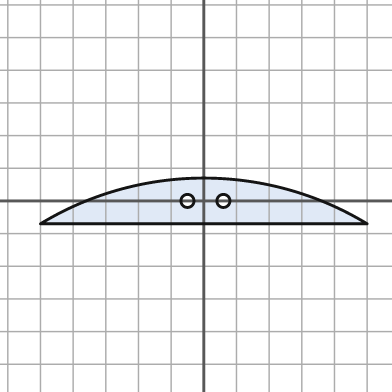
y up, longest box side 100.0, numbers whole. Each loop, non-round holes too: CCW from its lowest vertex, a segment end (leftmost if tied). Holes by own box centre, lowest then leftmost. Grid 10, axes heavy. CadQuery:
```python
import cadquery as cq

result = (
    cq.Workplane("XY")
    .moveTo(-50.0, -7.0)
    .lineTo(50.0, -7.0)
    .threePointArc((0.0, 7.0), (-50.0, -7.0))
    .close()
    .moveTo(-5.0, 0.0)
    .circle(2.0)
    .moveTo(6.0, 0.0)
    .circle(2.0)
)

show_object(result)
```